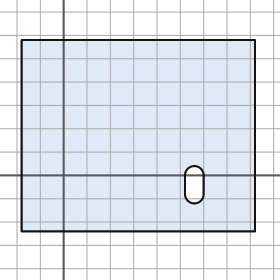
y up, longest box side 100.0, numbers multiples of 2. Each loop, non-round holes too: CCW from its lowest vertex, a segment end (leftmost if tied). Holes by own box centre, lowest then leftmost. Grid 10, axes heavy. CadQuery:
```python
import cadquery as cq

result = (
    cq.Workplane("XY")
    .moveTo(-18.0, -24.0)
    .lineTo(82.0, -24.0)
    .lineTo(82.0, 58.0)
    .lineTo(-18.0, 58.0)
    .close()
    .moveTo(52.0, -8.0)
    .threePointArc((56.0, -12.0), (60.0, -8.0))
    .lineTo(60.0, 0.0)
    .threePointArc((56.0, 4.0), (52.0, 0.0))
    .close()
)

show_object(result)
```